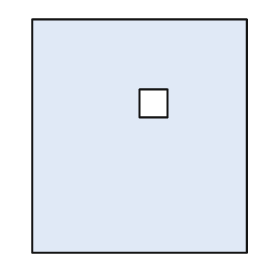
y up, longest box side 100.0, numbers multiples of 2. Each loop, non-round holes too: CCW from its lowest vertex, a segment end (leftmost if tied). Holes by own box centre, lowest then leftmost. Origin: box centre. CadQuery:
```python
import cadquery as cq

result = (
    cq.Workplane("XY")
    .moveTo(-46.0, -50.0)
    .lineTo(46.0, -50.0)
    .lineTo(46.0, 50.0)
    .lineTo(-46.0, 50.0)
    .close()
    .moveTo(0.0, 8.0)
    .lineTo(12.0, 8.0)
    .lineTo(12.0, 20.0)
    .lineTo(0.0, 20.0)
    .close()
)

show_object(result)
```